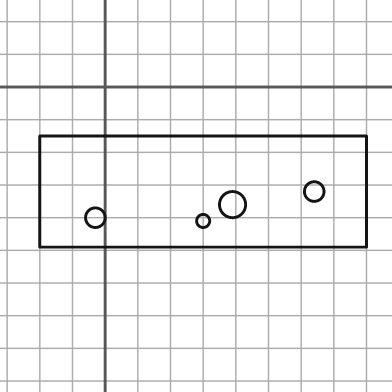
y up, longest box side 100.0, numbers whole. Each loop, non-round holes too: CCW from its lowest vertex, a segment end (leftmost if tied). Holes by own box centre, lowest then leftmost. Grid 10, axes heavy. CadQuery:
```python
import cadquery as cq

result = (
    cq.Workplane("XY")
    .moveTo(-20.0, -49.0)
    .lineTo(80.0, -49.0)
    .lineTo(80.0, -15.0)
    .lineTo(-20.0, -15.0)
    .close()
    .moveTo(30.0, -41.0)
    .circle(2.0)
    .moveTo(-3.0, -40.0)
    .circle(3.0)
    .moveTo(39.0, -36.0)
    .circle(4.0)
    .moveTo(64.0, -32.0)
    .circle(3.0)
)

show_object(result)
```